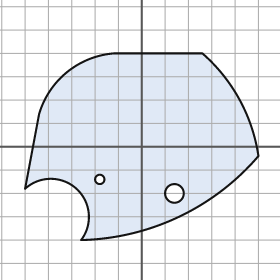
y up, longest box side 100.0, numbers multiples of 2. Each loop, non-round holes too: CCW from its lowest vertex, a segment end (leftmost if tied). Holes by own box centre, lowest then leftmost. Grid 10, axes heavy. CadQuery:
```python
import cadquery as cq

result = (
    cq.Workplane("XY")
    .moveTo(-26.0, -40.0)
    .threePointArc((16.0, -30.0), (50.0, -4.0))
    .threePointArc((42.0, 20.0), (26.0, 40.0))
    .lineTo(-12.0, 40.0)
    .threePointArc((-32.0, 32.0), (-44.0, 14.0))
    .lineTo(-50.0, -18.0)
    .threePointArc((-28.0, -18.0), (-26.0, -40.0))
    .close()
    .moveTo(14.0, -20.0)
    .circle(4.0)
    .moveTo(-18.0, -14.0)
    .circle(2.0)
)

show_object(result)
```